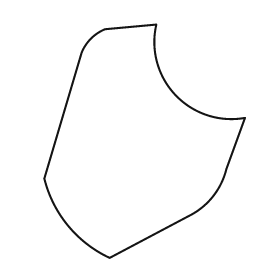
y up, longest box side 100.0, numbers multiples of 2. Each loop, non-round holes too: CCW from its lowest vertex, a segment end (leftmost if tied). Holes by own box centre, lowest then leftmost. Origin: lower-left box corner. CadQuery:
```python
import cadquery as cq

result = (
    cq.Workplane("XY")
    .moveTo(28.0, 0.0)
    .lineTo(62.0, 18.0)
    .threePointArc((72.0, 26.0), (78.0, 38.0))
    .lineTo(86.0, 60.0)
    .threePointArc((56.0, 70.0), (48.0, 100.0))
    .lineTo(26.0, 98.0)
    .threePointArc((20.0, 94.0), (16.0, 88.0))
    .lineTo(0.0, 34.0)
    .threePointArc((10.0, 14.0), (28.0, 0.0))
    .close()
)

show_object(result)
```